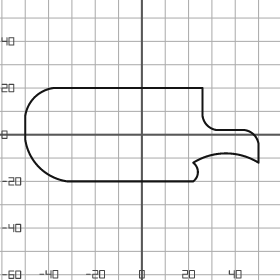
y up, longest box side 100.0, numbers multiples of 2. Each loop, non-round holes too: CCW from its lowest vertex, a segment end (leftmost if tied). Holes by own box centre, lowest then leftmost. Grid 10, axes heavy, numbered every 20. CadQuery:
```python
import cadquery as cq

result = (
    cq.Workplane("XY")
    .moveTo(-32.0, -20.0)
    .lineTo(22.0, -20.0)
    .threePointArc((24.0, -16.0), (22.0, -12.0))
    .threePointArc((36.0, -8.0), (50.0, -12.0))
    .lineTo(50.0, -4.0)
    .threePointArc((48.0, 0.0), (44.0, 2.0))
    .lineTo(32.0, 2.0)
    .threePointArc((28.0, 4.0), (26.0, 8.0))
    .lineTo(26.0, 20.0)
    .lineTo(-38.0, 20.0)
    .threePointArc((-46.0, 16.0), (-50.0, 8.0))
    .lineTo(-50.0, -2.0)
    .threePointArc((-44.0, -14.0), (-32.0, -20.0))
    .close()
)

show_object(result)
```